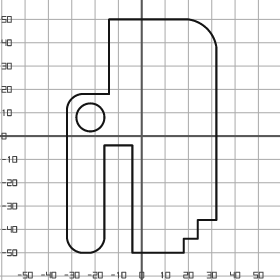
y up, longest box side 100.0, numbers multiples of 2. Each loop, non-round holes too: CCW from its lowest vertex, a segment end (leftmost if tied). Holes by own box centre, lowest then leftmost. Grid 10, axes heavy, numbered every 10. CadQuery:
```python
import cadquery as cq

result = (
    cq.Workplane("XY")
    .moveTo(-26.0, -50.0)
    .lineTo(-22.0, -50.0)
    .threePointArc((-18.0, -48.0), (-16.0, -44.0))
    .lineTo(-16.0, -4.0)
    .lineTo(-4.0, -4.0)
    .lineTo(-4.0, -50.0)
    .lineTo(18.0, -50.0)
    .lineTo(18.0, -44.0)
    .lineTo(24.0, -44.0)
    .lineTo(24.0, -36.0)
    .lineTo(32.0, -36.0)
    .lineTo(32.0, 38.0)
    .threePointArc((28.0, 46.0), (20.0, 50.0))
    .lineTo(-14.0, 50.0)
    .lineTo(-14.0, 18.0)
    .lineTo(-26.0, 18.0)
    .threePointArc((-30.0, 16.0), (-32.0, 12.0))
    .lineTo(-32.0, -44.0)
    .threePointArc((-30.0, -48.0), (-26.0, -50.0))
    .close()
    .moveTo(-22.0, 8.0)
    .circle(6.0)
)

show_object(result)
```